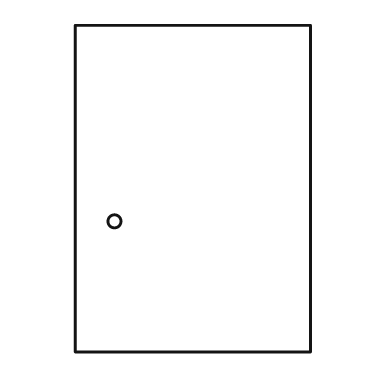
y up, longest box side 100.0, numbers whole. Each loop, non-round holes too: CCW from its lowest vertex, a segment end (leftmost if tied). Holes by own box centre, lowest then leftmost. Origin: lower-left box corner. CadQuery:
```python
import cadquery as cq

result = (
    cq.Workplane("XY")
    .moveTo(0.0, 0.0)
    .lineTo(72.0, 0.0)
    .lineTo(72.0, 100.0)
    .lineTo(0.0, 100.0)
    .close()
    .moveTo(12.0, 40.0)
    .circle(2.0)
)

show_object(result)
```